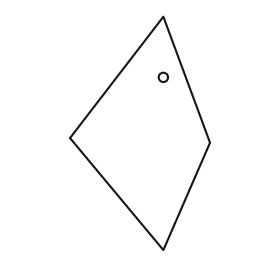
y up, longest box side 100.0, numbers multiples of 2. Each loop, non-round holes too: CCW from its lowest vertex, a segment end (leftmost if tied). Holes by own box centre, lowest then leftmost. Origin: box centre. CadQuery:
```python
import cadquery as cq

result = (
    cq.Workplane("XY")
    .moveTo(10.0, -50.0)
    .lineTo(30.0, -4.0)
    .lineTo(10.0, 50.0)
    .lineTo(-30.0, -2.0)
    .close()
    .moveTo(10.0, 24.0)
    .circle(2.0)
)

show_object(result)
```